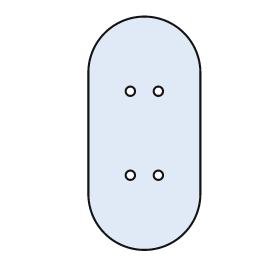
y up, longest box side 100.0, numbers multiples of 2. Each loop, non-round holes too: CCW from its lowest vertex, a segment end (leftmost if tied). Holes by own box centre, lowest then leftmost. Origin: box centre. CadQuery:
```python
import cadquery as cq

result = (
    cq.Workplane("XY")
    .moveTo(-24.0, -26.0)
    .threePointArc((0.0, -50.0), (24.0, -26.0))
    .lineTo(24.0, 26.0)
    .threePointArc((0.0, 50.0), (-24.0, 26.0))
    .close()
    .moveTo(-6.0, -18.0)
    .circle(2.0)
    .moveTo(6.0, -18.0)
    .circle(2.0)
    .moveTo(-6.0, 18.0)
    .circle(2.0)
    .moveTo(6.0, 18.0)
    .circle(2.0)
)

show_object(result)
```